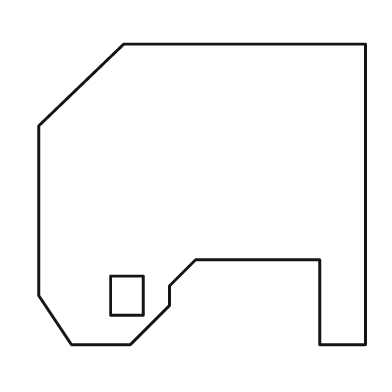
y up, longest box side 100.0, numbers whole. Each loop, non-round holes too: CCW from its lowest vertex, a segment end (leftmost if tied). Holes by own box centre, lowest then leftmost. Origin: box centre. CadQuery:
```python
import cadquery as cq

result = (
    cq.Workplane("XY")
    .moveTo(-40.0, -46.0)
    .lineTo(-22.0, -46.0)
    .lineTo(-10.0, -34.0)
    .lineTo(-10.0, -28.0)
    .lineTo(-2.0, -20.0)
    .lineTo(36.0, -20.0)
    .lineTo(36.0, -46.0)
    .lineTo(50.0, -46.0)
    .lineTo(50.0, 46.0)
    .lineTo(-24.0, 46.0)
    .lineTo(-50.0, 21.0)
    .lineTo(-50.0, -31.0)
    .close()
    .moveTo(-28.0, -37.0)
    .lineTo(-18.0, -37.0)
    .lineTo(-18.0, -25.0)
    .lineTo(-28.0, -25.0)
    .close()
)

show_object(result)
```